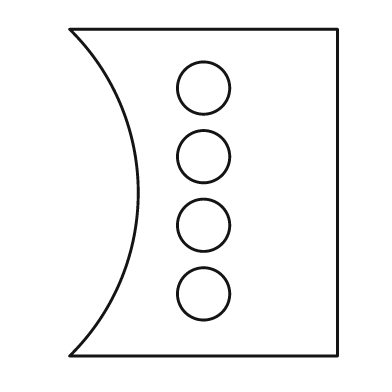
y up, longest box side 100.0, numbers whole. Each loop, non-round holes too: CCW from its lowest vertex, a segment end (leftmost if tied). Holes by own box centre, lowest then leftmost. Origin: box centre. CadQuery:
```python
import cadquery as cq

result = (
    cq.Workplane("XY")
    .moveTo(-41.0, -50.0)
    .lineTo(41.0, -50.0)
    .lineTo(41.0, 50.0)
    .lineTo(-41.0, 50.0)
    .threePointArc((-20.0, 0.0), (-41.0, -50.0))
    .close()
    .moveTo(0.0, -31.0)
    .circle(8.0)
    .moveTo(0.0, -10.0)
    .circle(8.0)
    .moveTo(0.0, 11.0)
    .circle(8.0)
    .moveTo(0.0, 32.0)
    .circle(8.0)
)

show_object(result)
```